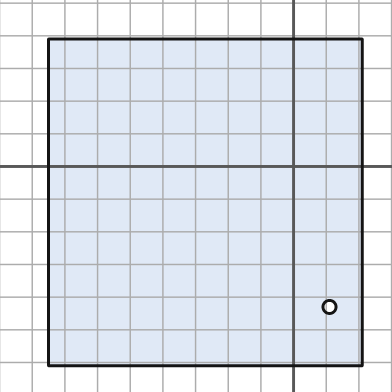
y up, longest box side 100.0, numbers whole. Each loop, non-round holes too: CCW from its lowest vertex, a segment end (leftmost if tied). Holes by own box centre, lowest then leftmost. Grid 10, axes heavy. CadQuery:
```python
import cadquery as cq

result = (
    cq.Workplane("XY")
    .moveTo(-75.0, -61.0)
    .lineTo(21.0, -61.0)
    .lineTo(21.0, 39.0)
    .lineTo(-75.0, 39.0)
    .close()
    .moveTo(11.0, -43.0)
    .circle(2.0)
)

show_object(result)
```